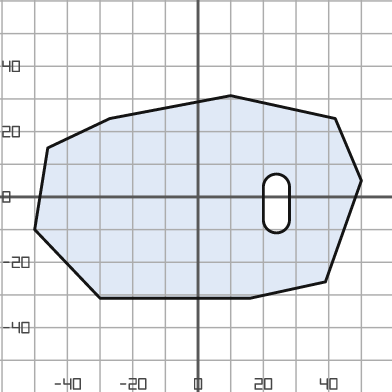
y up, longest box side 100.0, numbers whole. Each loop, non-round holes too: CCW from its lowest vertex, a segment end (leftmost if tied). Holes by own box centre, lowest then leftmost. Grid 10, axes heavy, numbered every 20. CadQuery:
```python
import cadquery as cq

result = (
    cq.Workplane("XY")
    .moveTo(-30.0, -31.0)
    .lineTo(16.0, -31.0)
    .lineTo(39.0, -26.0)
    .lineTo(50.0, 5.0)
    .lineTo(42.0, 24.0)
    .lineTo(10.0, 31.0)
    .lineTo(-27.0, 24.0)
    .lineTo(-46.0, 15.0)
    .lineTo(-50.0, -10.0)
    .close()
    .moveTo(20.0, -7.0)
    .threePointArc((24.0, -11.0), (28.0, -7.0))
    .lineTo(28.0, 3.0)
    .threePointArc((24.0, 7.0), (20.0, 3.0))
    .close()
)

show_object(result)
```